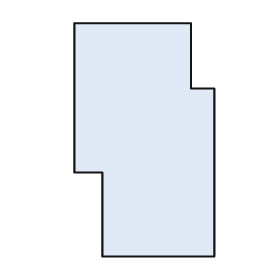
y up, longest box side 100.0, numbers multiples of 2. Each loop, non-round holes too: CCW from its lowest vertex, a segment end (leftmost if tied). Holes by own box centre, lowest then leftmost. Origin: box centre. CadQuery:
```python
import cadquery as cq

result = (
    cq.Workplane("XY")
    .moveTo(-18.0, -50.0)
    .lineTo(30.0, -50.0)
    .lineTo(30.0, 22.0)
    .lineTo(20.0, 22.0)
    .lineTo(20.0, 50.0)
    .lineTo(-30.0, 50.0)
    .lineTo(-30.0, -14.0)
    .lineTo(-18.0, -14.0)
    .close()
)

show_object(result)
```